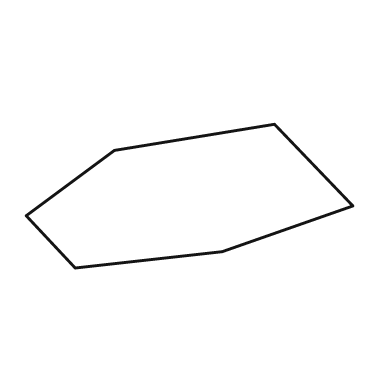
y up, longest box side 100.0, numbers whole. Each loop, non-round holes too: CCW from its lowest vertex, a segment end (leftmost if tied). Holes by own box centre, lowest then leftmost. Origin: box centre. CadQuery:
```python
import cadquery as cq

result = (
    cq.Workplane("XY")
    .moveTo(-35.0, -22.0)
    .lineTo(10.0, -17.0)
    .lineTo(50.0, -3.0)
    .lineTo(26.0, 22.0)
    .lineTo(-23.0, 14.0)
    .lineTo(-50.0, -6.0)
    .close()
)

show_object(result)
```